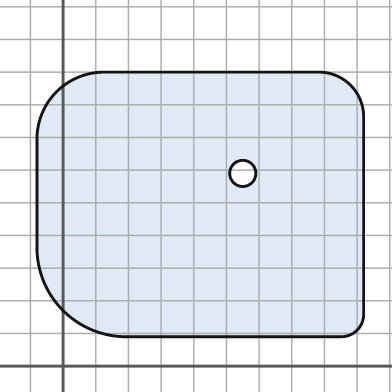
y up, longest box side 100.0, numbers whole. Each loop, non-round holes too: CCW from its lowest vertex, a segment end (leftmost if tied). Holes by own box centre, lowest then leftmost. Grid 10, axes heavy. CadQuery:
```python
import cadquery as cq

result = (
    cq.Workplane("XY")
    .moveTo(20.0, 9.0)
    .lineTo(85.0, 9.0)
    .threePointArc((90.0, 11.0), (92.0, 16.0))
    .lineTo(92.0, 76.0)
    .threePointArc((88.0, 86.0), (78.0, 90.0))
    .lineTo(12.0, 90.0)
    .threePointArc((-2.0, 84.0), (-8.0, 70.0))
    .lineTo(-8.0, 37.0)
    .threePointArc((0.0, 17.0), (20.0, 9.0))
    .close()
    .moveTo(55.0, 59.0)
    .circle(4.0)
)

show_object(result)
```